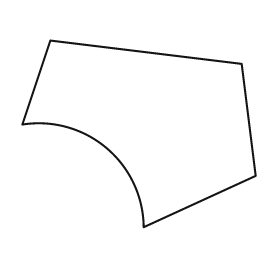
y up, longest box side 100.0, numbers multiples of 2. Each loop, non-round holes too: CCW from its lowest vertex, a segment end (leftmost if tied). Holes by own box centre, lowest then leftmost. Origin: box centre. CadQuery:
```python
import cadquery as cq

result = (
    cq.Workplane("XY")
    .moveTo(2.0, -40.0)
    .lineTo(50.0, -18.0)
    .lineTo(44.0, 30.0)
    .lineTo(-38.0, 40.0)
    .lineTo(-50.0, 4.0)
    .threePointArc((-14.0, -6.0), (2.0, -40.0))
    .close()
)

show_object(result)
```